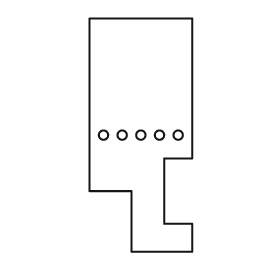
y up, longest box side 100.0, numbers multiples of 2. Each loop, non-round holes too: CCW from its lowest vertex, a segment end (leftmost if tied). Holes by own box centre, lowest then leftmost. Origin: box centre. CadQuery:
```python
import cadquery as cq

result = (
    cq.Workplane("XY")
    .moveTo(-4.0, -50.0)
    .lineTo(22.0, -50.0)
    .lineTo(22.0, -38.0)
    .lineTo(10.0, -38.0)
    .lineTo(10.0, -10.0)
    .lineTo(22.0, -10.0)
    .lineTo(22.0, 50.0)
    .lineTo(-22.0, 50.0)
    .lineTo(-22.0, -24.0)
    .lineTo(-4.0, -24.0)
    .close()
    .moveTo(-16.0, 0.0)
    .circle(2.0)
    .moveTo(-8.0, 0.0)
    .circle(2.0)
    .moveTo(0.0, 0.0)
    .circle(2.0)
    .moveTo(8.0, 0.0)
    .circle(2.0)
    .moveTo(16.0, 0.0)
    .circle(2.0)
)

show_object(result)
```